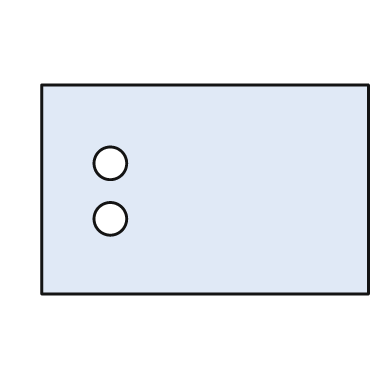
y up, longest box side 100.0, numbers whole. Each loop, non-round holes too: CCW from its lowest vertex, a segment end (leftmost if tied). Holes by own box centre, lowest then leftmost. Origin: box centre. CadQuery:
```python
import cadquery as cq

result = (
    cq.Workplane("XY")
    .moveTo(-50.0, -32.0)
    .lineTo(50.0, -32.0)
    .lineTo(50.0, 32.0)
    .lineTo(-50.0, 32.0)
    .close()
    .moveTo(-29.0, -9.0)
    .circle(5.0)
    .moveTo(-29.0, 8.0)
    .circle(5.0)
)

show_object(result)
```